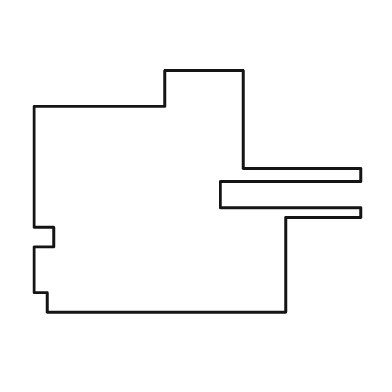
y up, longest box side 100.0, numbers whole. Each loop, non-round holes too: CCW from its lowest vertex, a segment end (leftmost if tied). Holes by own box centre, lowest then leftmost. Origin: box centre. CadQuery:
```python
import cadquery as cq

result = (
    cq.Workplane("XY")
    .moveTo(-46.0, -37.0)
    .lineTo(27.0, -37.0)
    .lineTo(27.0, -8.0)
    .lineTo(50.0, -8.0)
    .lineTo(50.0, -5.0)
    .lineTo(7.0, -5.0)
    .lineTo(7.0, 3.0)
    .lineTo(50.0, 3.0)
    .lineTo(50.0, 7.0)
    .lineTo(14.0, 7.0)
    .lineTo(14.0, 37.0)
    .lineTo(-10.0, 37.0)
    .lineTo(-10.0, 26.0)
    .lineTo(-50.0, 26.0)
    .lineTo(-50.0, -11.0)
    .lineTo(-44.0, -11.0)
    .lineTo(-44.0, -17.0)
    .lineTo(-50.0, -17.0)
    .lineTo(-50.0, -31.0)
    .lineTo(-46.0, -31.0)
    .close()
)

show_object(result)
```